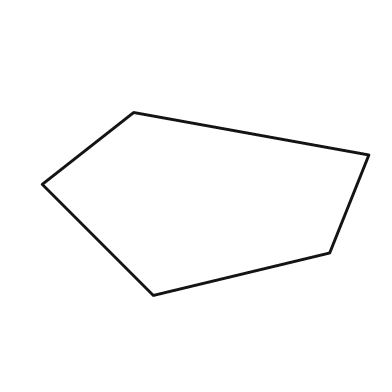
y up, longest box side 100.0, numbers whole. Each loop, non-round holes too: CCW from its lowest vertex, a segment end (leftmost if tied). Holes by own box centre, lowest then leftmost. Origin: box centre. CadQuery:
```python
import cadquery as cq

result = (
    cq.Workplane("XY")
    .moveTo(-16.0, -28.0)
    .lineTo(38.0, -15.0)
    .lineTo(50.0, 15.0)
    .lineTo(-22.0, 28.0)
    .lineTo(-50.0, 6.0)
    .close()
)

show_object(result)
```